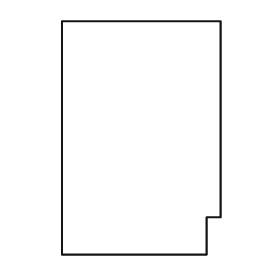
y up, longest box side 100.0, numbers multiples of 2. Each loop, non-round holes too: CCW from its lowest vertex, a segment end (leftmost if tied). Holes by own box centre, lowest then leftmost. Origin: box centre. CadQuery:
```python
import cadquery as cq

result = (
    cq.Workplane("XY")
    .moveTo(-34.0, -50.0)
    .lineTo(28.0, -50.0)
    .lineTo(28.0, -34.0)
    .lineTo(34.0, -34.0)
    .lineTo(34.0, 50.0)
    .lineTo(-34.0, 50.0)
    .close()
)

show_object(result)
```